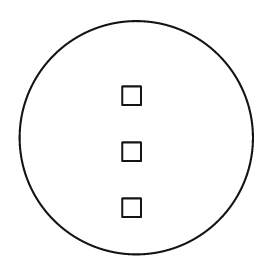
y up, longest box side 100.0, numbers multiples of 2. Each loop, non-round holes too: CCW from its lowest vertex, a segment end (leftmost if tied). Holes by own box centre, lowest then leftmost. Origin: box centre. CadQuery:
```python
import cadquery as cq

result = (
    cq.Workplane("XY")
    .moveTo(0.0, 0.0)
    .circle(50.0)
    .moveTo(-6.0, -34.0)
    .lineTo(2.0, -34.0)
    .lineTo(2.0, -26.0)
    .lineTo(-6.0, -26.0)
    .close()
    .moveTo(-6.0, -10.0)
    .lineTo(2.0, -10.0)
    .lineTo(2.0, -2.0)
    .lineTo(-6.0, -2.0)
    .close()
    .moveTo(-6.0, 14.0)
    .lineTo(2.0, 14.0)
    .lineTo(2.0, 22.0)
    .lineTo(-6.0, 22.0)
    .close()
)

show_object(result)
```